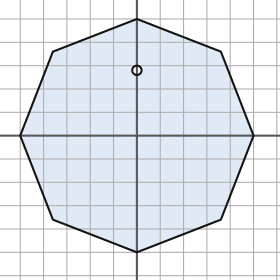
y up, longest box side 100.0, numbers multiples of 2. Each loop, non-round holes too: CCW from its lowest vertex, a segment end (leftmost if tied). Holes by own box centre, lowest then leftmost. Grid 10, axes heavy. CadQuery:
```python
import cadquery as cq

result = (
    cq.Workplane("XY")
    .moveTo(0.0, -50.0)
    .lineTo(36.0, -36.0)
    .lineTo(50.0, 0.0)
    .lineTo(36.0, 36.0)
    .lineTo(0.0, 50.0)
    .lineTo(-36.0, 36.0)
    .lineTo(-50.0, 0.0)
    .lineTo(-36.0, -36.0)
    .close()
    .moveTo(0.0, 28.0)
    .circle(2.0)
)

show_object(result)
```